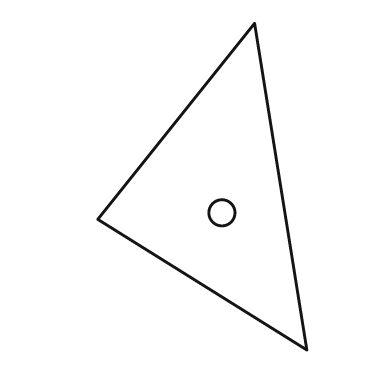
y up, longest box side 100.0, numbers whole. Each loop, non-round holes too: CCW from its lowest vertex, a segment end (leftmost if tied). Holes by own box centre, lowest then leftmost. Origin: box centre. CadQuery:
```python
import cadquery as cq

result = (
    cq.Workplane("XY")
    .moveTo(32.0, -50.0)
    .lineTo(16.0, 50.0)
    .lineTo(-32.0, -10.0)
    .close()
    .moveTo(6.0, -8.0)
    .circle(4.0)
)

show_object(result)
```